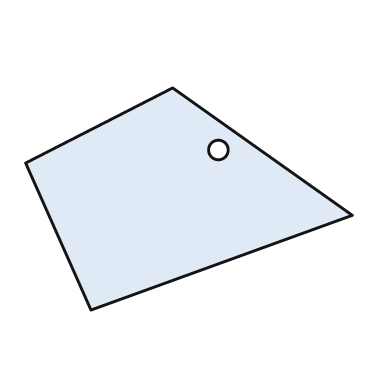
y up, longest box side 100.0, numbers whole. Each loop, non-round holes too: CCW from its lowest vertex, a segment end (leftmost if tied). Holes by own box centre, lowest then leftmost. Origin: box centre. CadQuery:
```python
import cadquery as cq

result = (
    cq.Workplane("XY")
    .moveTo(-30.0, -34.0)
    .lineTo(50.0, -5.0)
    .lineTo(-5.0, 34.0)
    .lineTo(-50.0, 11.0)
    .close()
    .moveTo(9.0, 15.0)
    .circle(3.0)
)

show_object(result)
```